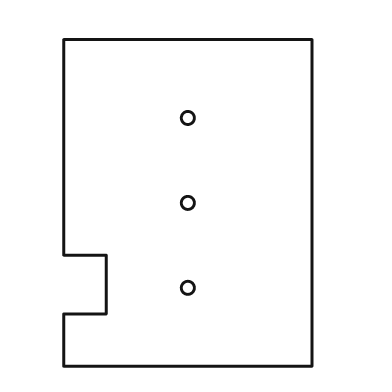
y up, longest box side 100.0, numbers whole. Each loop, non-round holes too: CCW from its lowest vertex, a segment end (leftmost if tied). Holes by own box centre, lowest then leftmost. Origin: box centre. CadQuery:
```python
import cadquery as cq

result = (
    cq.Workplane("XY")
    .moveTo(-38.0, -50.0)
    .lineTo(38.0, -50.0)
    .lineTo(38.0, 50.0)
    .lineTo(-38.0, 50.0)
    .lineTo(-38.0, -16.0)
    .lineTo(-25.0, -16.0)
    .lineTo(-25.0, -34.0)
    .lineTo(-38.0, -34.0)
    .close()
    .moveTo(0.0, -26.0)
    .circle(2.0)
    .moveTo(0.0, 0.0)
    .circle(2.0)
    .moveTo(0.0, 26.0)
    .circle(2.0)
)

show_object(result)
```